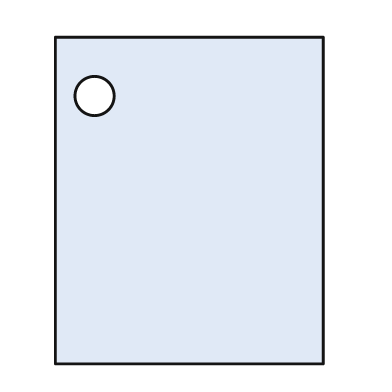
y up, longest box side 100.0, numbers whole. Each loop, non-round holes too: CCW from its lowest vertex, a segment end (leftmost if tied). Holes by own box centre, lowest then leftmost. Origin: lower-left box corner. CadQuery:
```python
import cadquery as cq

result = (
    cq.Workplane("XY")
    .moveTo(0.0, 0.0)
    .lineTo(82.0, 0.0)
    .lineTo(82.0, 100.0)
    .lineTo(0.0, 100.0)
    .close()
    .moveTo(12.0, 82.0)
    .circle(6.0)
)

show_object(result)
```